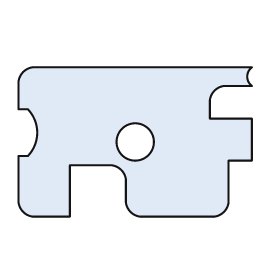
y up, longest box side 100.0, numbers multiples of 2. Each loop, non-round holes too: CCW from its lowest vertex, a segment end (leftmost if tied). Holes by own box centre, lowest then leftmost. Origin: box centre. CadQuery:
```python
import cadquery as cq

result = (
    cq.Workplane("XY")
    .moveTo(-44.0, -32.0)
    .lineTo(-28.0, -32.0)
    .lineTo(-28.0, -10.0)
    .lineTo(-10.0, -10.0)
    .threePointArc((-6.0, -12.0), (-4.0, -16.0))
    .lineTo(-4.0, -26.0)
    .threePointArc((-2.0, -30.0), (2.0, -32.0))
    .lineTo(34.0, -32.0)
    .threePointArc((38.0, -30.0), (40.0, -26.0))
    .lineTo(40.0, -8.0)
    .lineTo(50.0, -8.0)
    .lineTo(50.0, 10.0)
    .lineTo(32.0, 10.0)
    .lineTo(32.0, 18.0)
    .threePointArc((34.0, 22.0), (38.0, 24.0))
    .lineTo(50.0, 24.0)
    .threePointArc((48.0, 28.0), (50.0, 32.0))
    .lineTo(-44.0, 32.0)
    .threePointArc((-48.0, 30.0), (-50.0, 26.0))
    .lineTo(-50.0, 14.0)
    .lineTo(-46.0, 14.0)
    .threePointArc((-42.0, 4.0), (-46.0, -6.0))
    .lineTo(-50.0, -6.0)
    .lineTo(-50.0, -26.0)
    .threePointArc((-48.0, -30.0), (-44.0, -32.0))
    .close()
    .moveTo(0.0, 0.0)
    .circle(8.0)
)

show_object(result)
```